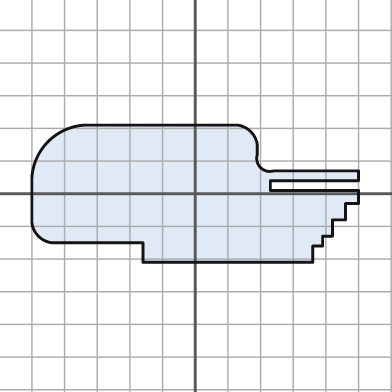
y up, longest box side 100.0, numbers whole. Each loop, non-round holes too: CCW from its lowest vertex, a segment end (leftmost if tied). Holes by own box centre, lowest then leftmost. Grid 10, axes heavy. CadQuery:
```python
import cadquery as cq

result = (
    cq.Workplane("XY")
    .moveTo(-16.0, -21.0)
    .lineTo(36.0, -21.0)
    .lineTo(36.0, -16.0)
    .lineTo(39.0, -16.0)
    .lineTo(39.0, -13.0)
    .lineTo(42.0, -13.0)
    .lineTo(42.0, -8.0)
    .lineTo(46.0, -8.0)
    .lineTo(46.0, -3.0)
    .lineTo(50.0, -3.0)
    .lineTo(50.0, 1.0)
    .lineTo(23.0, 1.0)
    .lineTo(23.0, 4.0)
    .lineTo(50.0, 4.0)
    .lineTo(50.0, 7.0)
    .lineTo(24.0, 7.0)
    .threePointArc((20.0, 8.0), (19.0, 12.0))
    .lineTo(19.0, 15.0)
    .threePointArc((17.0, 19.0), (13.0, 21.0))
    .lineTo(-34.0, 21.0)
    .threePointArc((-45.0, 16.0), (-50.0, 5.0))
    .lineTo(-50.0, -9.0)
    .threePointArc((-48.0, -13.0), (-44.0, -15.0))
    .lineTo(-16.0, -15.0)
    .close()
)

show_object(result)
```